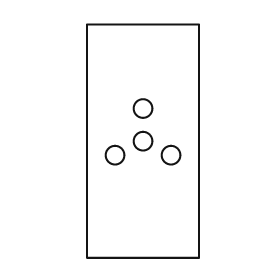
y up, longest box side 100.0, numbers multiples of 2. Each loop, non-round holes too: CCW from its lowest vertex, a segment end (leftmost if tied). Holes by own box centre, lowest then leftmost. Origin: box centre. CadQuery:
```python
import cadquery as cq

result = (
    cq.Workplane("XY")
    .moveTo(-24.0, -50.0)
    .lineTo(24.0, -50.0)
    .lineTo(24.0, 50.0)
    .lineTo(-24.0, 50.0)
    .close()
    .moveTo(-12.0, -6.0)
    .circle(4.0)
    .moveTo(12.0, -6.0)
    .circle(4.0)
    .moveTo(0.0, 0.0)
    .circle(4.0)
    .moveTo(0.0, 14.0)
    .circle(4.0)
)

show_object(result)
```